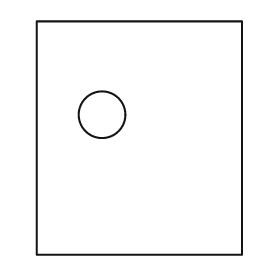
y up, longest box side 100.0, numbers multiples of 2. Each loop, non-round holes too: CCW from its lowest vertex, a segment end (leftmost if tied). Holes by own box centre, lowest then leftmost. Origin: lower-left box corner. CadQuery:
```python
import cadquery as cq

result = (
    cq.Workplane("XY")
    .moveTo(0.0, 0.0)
    .lineTo(88.0, 0.0)
    .lineTo(88.0, 100.0)
    .lineTo(0.0, 100.0)
    .close()
    .moveTo(28.0, 60.0)
    .circle(10.0)
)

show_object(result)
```